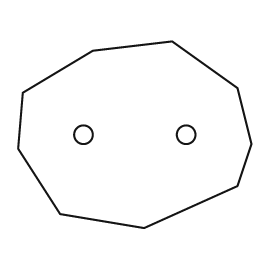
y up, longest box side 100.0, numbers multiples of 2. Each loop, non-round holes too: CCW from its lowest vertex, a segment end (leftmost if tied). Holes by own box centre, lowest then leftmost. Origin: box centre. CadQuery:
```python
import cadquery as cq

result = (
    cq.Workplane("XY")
    .moveTo(4.0, -40.0)
    .lineTo(44.0, -22.0)
    .lineTo(50.0, -4.0)
    .lineTo(44.0, 20.0)
    .lineTo(16.0, 40.0)
    .lineTo(-18.0, 36.0)
    .lineTo(-48.0, 18.0)
    .lineTo(-50.0, -6.0)
    .lineTo(-32.0, -34.0)
    .close()
    .moveTo(-22.0, 0.0)
    .circle(4.0)
    .moveTo(22.0, 0.0)
    .circle(4.0)
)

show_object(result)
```